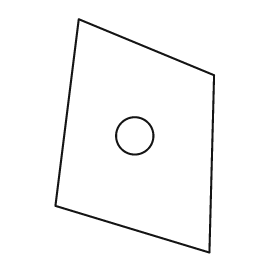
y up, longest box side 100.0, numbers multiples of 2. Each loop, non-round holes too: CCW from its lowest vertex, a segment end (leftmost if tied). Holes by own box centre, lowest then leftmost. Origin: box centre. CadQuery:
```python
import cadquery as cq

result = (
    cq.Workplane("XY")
    .moveTo(32.0, -50.0)
    .lineTo(34.0, 26.0)
    .lineTo(-24.0, 50.0)
    .lineTo(-34.0, -30.0)
    .close()
    .moveTo(0.0, 0.0)
    .circle(8.0)
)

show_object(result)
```